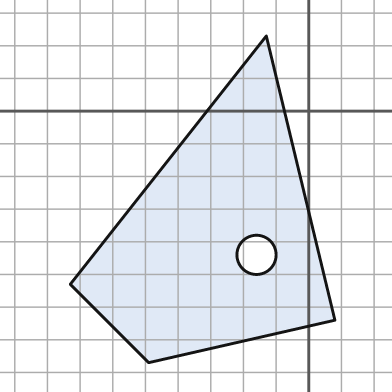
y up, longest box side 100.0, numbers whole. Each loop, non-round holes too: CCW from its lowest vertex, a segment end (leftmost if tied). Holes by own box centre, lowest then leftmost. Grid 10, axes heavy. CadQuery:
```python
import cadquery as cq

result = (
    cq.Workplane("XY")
    .moveTo(-49.0, -77.0)
    .lineTo(8.0, -64.0)
    .lineTo(-13.0, 23.0)
    .lineTo(-73.0, -53.0)
    .close()
    .moveTo(-16.0, -44.0)
    .circle(6.0)
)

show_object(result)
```